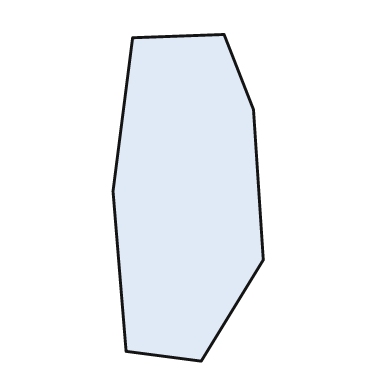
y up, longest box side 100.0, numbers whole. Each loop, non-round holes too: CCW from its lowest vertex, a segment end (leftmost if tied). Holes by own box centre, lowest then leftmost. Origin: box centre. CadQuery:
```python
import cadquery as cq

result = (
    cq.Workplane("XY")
    .moveTo(4.0, -50.0)
    .lineTo(23.0, -19.0)
    .lineTo(20.0, 27.0)
    .lineTo(11.0, 50.0)
    .lineTo(-17.0, 49.0)
    .lineTo(-23.0, 2.0)
    .lineTo(-19.0, -47.0)
    .close()
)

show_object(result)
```